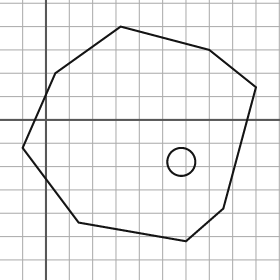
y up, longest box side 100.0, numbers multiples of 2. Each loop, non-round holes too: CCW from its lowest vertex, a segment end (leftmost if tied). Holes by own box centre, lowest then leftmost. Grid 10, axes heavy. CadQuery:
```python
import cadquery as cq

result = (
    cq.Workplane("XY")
    .moveTo(60.0, -52.0)
    .lineTo(76.0, -38.0)
    .lineTo(90.0, 14.0)
    .lineTo(70.0, 30.0)
    .lineTo(32.0, 40.0)
    .lineTo(4.0, 20.0)
    .lineTo(-10.0, -12.0)
    .lineTo(14.0, -44.0)
    .close()
    .moveTo(58.0, -18.0)
    .circle(6.0)
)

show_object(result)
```